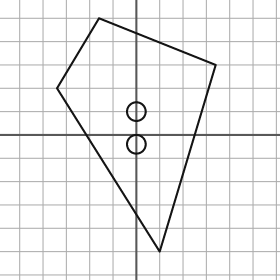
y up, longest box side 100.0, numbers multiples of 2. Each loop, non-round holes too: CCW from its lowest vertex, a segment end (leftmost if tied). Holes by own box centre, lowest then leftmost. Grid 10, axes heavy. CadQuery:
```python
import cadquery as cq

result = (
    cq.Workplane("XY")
    .moveTo(10.0, -50.0)
    .lineTo(34.0, 30.0)
    .lineTo(-16.0, 50.0)
    .lineTo(-34.0, 20.0)
    .close()
    .moveTo(0.0, -4.0)
    .circle(4.0)
    .moveTo(0.0, 10.0)
    .circle(4.0)
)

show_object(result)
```